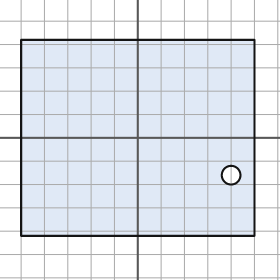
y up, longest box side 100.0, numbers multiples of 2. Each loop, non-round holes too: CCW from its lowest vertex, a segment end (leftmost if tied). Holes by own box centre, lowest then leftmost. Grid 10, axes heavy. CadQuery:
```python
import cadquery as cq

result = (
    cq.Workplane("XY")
    .moveTo(-50.0, -42.0)
    .lineTo(50.0, -42.0)
    .lineTo(50.0, 42.0)
    .lineTo(-50.0, 42.0)
    .close()
    .moveTo(40.0, -16.0)
    .circle(4.0)
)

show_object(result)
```